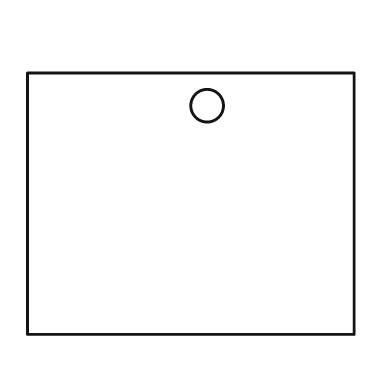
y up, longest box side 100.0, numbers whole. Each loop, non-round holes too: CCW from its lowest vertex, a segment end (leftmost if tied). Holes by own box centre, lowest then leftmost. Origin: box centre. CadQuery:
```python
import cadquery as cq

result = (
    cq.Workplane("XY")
    .moveTo(-50.0, -40.0)
    .lineTo(50.0, -40.0)
    .lineTo(50.0, 40.0)
    .lineTo(-50.0, 40.0)
    .close()
    .moveTo(5.0, 30.0)
    .circle(5.0)
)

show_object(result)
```